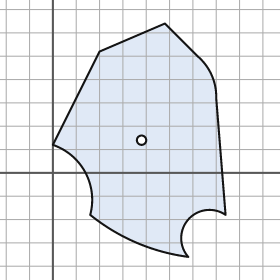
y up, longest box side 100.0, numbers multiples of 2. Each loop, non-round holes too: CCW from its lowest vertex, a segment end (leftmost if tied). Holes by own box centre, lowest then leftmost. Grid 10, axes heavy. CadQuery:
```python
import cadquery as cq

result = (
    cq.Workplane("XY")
    .moveTo(58.0, -36.0)
    .threePointArc((58.0, -20.0), (74.0, -18.0))
    .lineTo(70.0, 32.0)
    .threePointArc((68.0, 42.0), (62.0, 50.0))
    .lineTo(48.0, 64.0)
    .lineTo(20.0, 52.0)
    .lineTo(0.0, 12.0)
    .threePointArc((14.0, 0.0), (16.0, -18.0))
    .threePointArc((36.0, -30.0), (58.0, -36.0))
    .close()
    .moveTo(38.0, 14.0)
    .circle(2.0)
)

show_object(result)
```